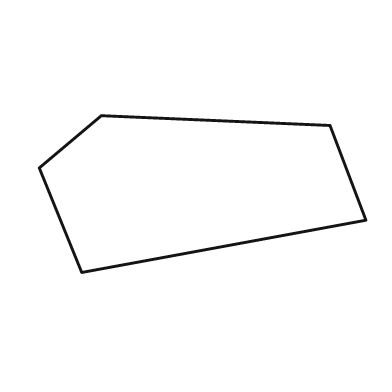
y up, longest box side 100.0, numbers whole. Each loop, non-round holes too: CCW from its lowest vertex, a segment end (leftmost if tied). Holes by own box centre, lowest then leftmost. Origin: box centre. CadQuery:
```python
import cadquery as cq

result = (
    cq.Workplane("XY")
    .moveTo(-37.0, -24.0)
    .lineTo(50.0, -8.0)
    .lineTo(39.0, 21.0)
    .lineTo(-31.0, 24.0)
    .lineTo(-50.0, 8.0)
    .close()
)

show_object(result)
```